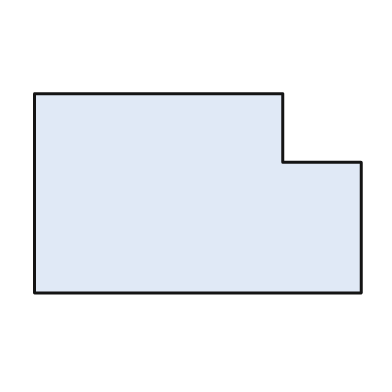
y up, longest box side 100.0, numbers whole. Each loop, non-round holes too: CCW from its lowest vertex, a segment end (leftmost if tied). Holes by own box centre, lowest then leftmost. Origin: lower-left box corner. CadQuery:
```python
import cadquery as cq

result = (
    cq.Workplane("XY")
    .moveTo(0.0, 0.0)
    .lineTo(100.0, 0.0)
    .lineTo(100.0, 40.0)
    .lineTo(76.0, 40.0)
    .lineTo(76.0, 61.0)
    .lineTo(0.0, 61.0)
    .close()
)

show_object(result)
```